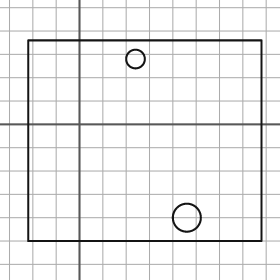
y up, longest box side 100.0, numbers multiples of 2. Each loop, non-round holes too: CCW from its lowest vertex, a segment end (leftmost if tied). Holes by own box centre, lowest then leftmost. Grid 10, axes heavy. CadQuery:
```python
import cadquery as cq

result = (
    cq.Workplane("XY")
    .moveTo(-22.0, -50.0)
    .lineTo(78.0, -50.0)
    .lineTo(78.0, 36.0)
    .lineTo(-22.0, 36.0)
    .close()
    .moveTo(46.0, -40.0)
    .circle(6.0)
    .moveTo(24.0, 28.0)
    .circle(4.0)
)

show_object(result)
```